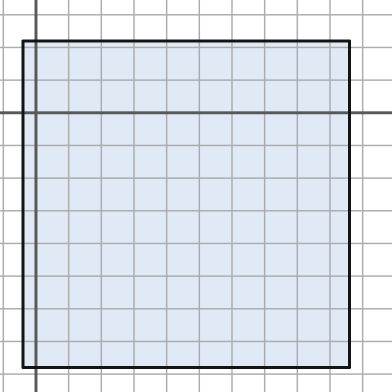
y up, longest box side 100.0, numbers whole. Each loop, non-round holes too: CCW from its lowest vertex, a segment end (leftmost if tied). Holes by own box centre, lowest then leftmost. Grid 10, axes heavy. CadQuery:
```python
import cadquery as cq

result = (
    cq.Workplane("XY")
    .moveTo(-4.0, -78.0)
    .lineTo(96.0, -78.0)
    .lineTo(96.0, 22.0)
    .lineTo(-4.0, 22.0)
    .close()
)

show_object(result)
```